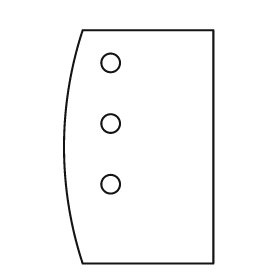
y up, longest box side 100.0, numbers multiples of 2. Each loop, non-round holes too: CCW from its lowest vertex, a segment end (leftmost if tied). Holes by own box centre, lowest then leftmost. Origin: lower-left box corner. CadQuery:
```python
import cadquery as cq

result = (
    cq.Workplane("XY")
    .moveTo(8.0, 0.0)
    .lineTo(64.0, 0.0)
    .lineTo(64.0, 100.0)
    .lineTo(8.0, 100.0)
    .threePointArc((0.0, 50.0), (8.0, 0.0))
    .close()
    .moveTo(20.0, 34.0)
    .circle(4.0)
    .moveTo(20.0, 60.0)
    .circle(4.0)
    .moveTo(20.0, 86.0)
    .circle(4.0)
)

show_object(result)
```